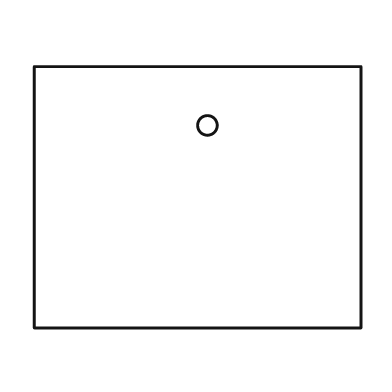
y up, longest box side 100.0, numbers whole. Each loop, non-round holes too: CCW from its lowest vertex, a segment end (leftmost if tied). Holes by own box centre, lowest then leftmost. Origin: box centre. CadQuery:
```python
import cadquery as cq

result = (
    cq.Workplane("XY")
    .moveTo(-50.0, -40.0)
    .lineTo(50.0, -40.0)
    .lineTo(50.0, 40.0)
    .lineTo(-50.0, 40.0)
    .close()
    .moveTo(3.0, 22.0)
    .circle(3.0)
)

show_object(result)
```